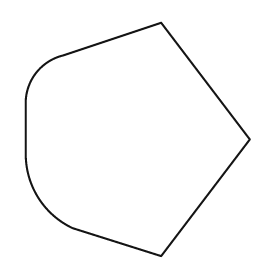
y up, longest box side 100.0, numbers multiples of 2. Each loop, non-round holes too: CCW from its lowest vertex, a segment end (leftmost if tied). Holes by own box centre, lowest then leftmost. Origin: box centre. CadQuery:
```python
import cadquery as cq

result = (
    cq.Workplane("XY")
    .moveTo(10.0, -50.0)
    .lineTo(48.0, 0.0)
    .lineTo(10.0, 50.0)
    .lineTo(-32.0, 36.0)
    .threePointArc((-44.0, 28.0), (-48.0, 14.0))
    .lineTo(-48.0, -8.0)
    .threePointArc((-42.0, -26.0), (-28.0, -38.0))
    .close()
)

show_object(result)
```